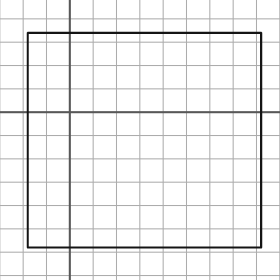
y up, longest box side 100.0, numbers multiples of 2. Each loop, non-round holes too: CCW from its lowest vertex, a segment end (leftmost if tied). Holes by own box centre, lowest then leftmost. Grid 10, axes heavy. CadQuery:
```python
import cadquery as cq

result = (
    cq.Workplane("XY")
    .moveTo(-18.0, -58.0)
    .lineTo(82.0, -58.0)
    .lineTo(82.0, 34.0)
    .lineTo(-18.0, 34.0)
    .close()
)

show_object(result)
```